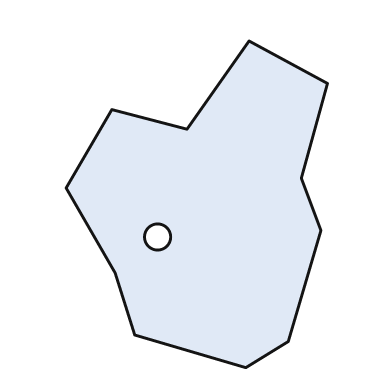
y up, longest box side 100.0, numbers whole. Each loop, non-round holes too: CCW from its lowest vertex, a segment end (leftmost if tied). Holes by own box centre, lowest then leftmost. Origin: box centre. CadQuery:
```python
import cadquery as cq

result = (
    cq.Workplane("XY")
    .moveTo(15.0, -50.0)
    .lineTo(28.0, -42.0)
    .lineTo(38.0, -8.0)
    .lineTo(32.0, 8.0)
    .lineTo(40.0, 37.0)
    .lineTo(16.0, 50.0)
    .lineTo(-3.0, 23.0)
    .lineTo(-26.0, 29.0)
    .lineTo(-40.0, 5.0)
    .lineTo(-25.0, -21.0)
    .lineTo(-19.0, -40.0)
    .close()
    .moveTo(-12.0, -10.0)
    .circle(4.0)
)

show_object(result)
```